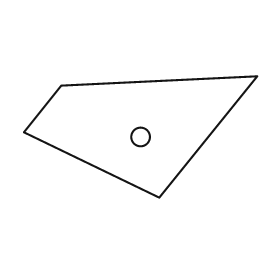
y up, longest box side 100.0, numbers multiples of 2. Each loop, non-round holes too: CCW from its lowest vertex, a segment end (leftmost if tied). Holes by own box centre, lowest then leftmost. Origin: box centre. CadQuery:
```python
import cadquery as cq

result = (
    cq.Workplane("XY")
    .moveTo(8.0, -26.0)
    .lineTo(50.0, 26.0)
    .lineTo(-34.0, 22.0)
    .lineTo(-50.0, 2.0)
    .close()
    .moveTo(0.0, 0.0)
    .circle(4.0)
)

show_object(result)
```